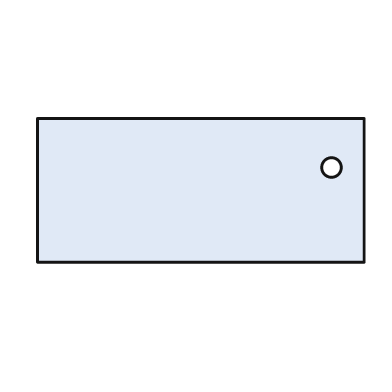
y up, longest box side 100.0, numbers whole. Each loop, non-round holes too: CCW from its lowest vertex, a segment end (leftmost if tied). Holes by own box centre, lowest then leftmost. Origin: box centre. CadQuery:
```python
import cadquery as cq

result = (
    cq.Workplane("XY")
    .moveTo(-50.0, -22.0)
    .lineTo(50.0, -22.0)
    .lineTo(50.0, 22.0)
    .lineTo(-50.0, 22.0)
    .close()
    .moveTo(40.0, 7.0)
    .circle(3.0)
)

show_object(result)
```